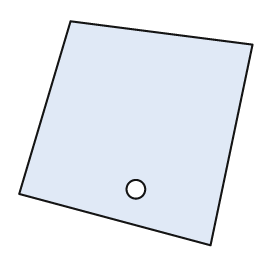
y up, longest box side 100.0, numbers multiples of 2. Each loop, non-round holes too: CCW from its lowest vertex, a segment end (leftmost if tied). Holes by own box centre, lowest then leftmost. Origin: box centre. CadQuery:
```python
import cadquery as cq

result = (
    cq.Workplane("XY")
    .moveTo(32.0, -48.0)
    .lineTo(50.0, 38.0)
    .lineTo(-28.0, 48.0)
    .lineTo(-50.0, -26.0)
    .close()
    .moveTo(0.0, -24.0)
    .circle(4.0)
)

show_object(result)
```